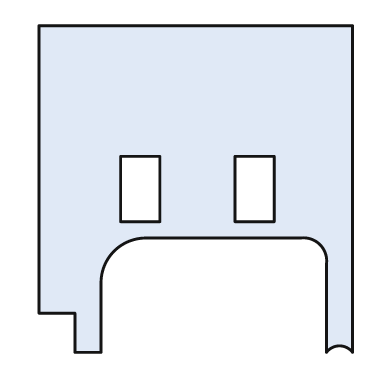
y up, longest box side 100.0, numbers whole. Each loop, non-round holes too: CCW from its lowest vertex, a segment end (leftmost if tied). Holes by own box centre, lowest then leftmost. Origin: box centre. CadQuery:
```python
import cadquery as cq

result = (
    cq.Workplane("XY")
    .moveTo(-37.0, -50.0)
    .lineTo(-29.0, -50.0)
    .lineTo(-29.0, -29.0)
    .threePointArc((-25.0, -19.0), (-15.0, -15.0))
    .lineTo(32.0, -15.0)
    .threePointArc((38.0, -17.0), (40.0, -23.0))
    .lineTo(40.0, -50.0)
    .threePointArc((44.0, -48.0), (48.0, -50.0))
    .lineTo(48.0, 50.0)
    .lineTo(-48.0, 50.0)
    .lineTo(-48.0, -38.0)
    .lineTo(-37.0, -38.0)
    .close()
    .moveTo(-23.0, -10.0)
    .lineTo(-11.0, -10.0)
    .lineTo(-11.0, 10.0)
    .lineTo(-23.0, 10.0)
    .close()
    .moveTo(12.0, -10.0)
    .lineTo(24.0, -10.0)
    .lineTo(24.0, 10.0)
    .lineTo(12.0, 10.0)
    .close()
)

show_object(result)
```